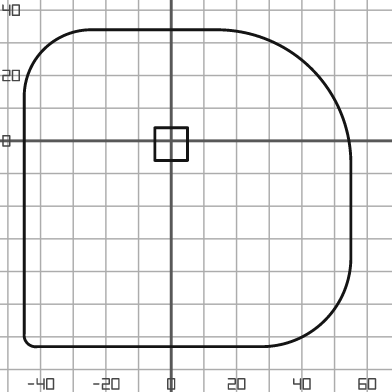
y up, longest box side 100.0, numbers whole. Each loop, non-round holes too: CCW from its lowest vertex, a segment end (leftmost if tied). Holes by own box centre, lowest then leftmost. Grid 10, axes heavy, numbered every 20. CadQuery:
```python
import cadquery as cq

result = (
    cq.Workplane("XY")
    .moveTo(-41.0, -63.0)
    .lineTo(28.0, -63.0)
    .threePointArc((47.0, -55.0), (55.0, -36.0))
    .lineTo(55.0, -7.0)
    .threePointArc((43.0, 22.0), (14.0, 34.0))
    .lineTo(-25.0, 34.0)
    .threePointArc((-39.0, 28.0), (-45.0, 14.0))
    .lineTo(-45.0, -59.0)
    .threePointArc((-44.0, -62.0), (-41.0, -63.0))
    .close()
    .moveTo(-5.0, -6.0)
    .lineTo(5.0, -6.0)
    .lineTo(5.0, 4.0)
    .lineTo(-5.0, 4.0)
    .close()
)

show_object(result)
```